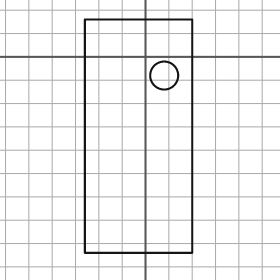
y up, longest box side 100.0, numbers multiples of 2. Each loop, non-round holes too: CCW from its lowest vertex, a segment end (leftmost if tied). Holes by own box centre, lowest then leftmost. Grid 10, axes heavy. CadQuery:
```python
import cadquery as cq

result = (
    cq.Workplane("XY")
    .moveTo(-26.0, -84.0)
    .lineTo(20.0, -84.0)
    .lineTo(20.0, 16.0)
    .lineTo(-26.0, 16.0)
    .close()
    .moveTo(8.0, -8.0)
    .circle(6.0)
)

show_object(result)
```